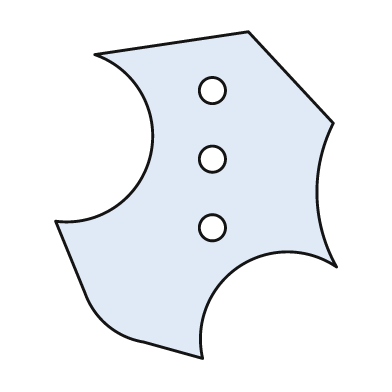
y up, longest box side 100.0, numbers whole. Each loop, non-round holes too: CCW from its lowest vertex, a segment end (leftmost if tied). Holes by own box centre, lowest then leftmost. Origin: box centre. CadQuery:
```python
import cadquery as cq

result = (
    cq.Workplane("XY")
    .moveTo(2.0, -50.0)
    .threePointArc((13.0, -22.0), (43.0, -22.0))
    .threePointArc((37.0, 0.0), (42.0, 22.0))
    .lineTo(16.0, 50.0)
    .lineTo(-31.0, 43.0)
    .threePointArc((-14.0, 12.0), (-43.0, -8.0))
    .lineTo(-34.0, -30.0)
    .threePointArc((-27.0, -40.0), (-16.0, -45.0))
    .close()
    .moveTo(5.0, -10.0)
    .circle(4.0)
    .moveTo(5.0, 11.0)
    .circle(4.0)
    .moveTo(5.0, 32.0)
    .circle(4.0)
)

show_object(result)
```